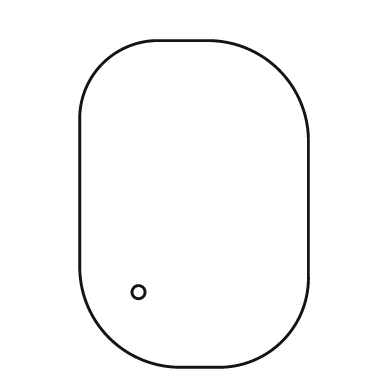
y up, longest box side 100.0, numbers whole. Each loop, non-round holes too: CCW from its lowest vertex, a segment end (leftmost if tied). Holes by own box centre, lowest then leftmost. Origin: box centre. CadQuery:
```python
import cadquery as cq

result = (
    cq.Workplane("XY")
    .moveTo(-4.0, -50.0)
    .lineTo(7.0, -50.0)
    .threePointArc((27.0, -42.0), (35.0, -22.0))
    .lineTo(35.0, 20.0)
    .threePointArc((26.0, 41.0), (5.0, 50.0))
    .lineTo(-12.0, 50.0)
    .threePointArc((-28.0, 43.0), (-35.0, 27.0))
    .lineTo(-35.0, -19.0)
    .threePointArc((-26.0, -41.0), (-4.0, -50.0))
    .close()
    .moveTo(-17.0, -27.0)
    .circle(2.0)
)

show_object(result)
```